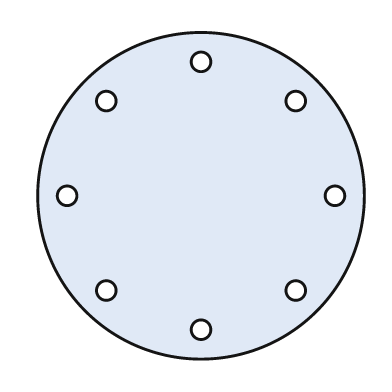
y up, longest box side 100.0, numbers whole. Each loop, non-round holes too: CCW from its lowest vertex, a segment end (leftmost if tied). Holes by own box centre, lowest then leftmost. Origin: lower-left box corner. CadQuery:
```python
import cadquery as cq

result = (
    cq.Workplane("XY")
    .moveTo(50.0, 50.0)
    .circle(50.0)
    .moveTo(50.0, 9.0)
    .circle(3.0)
    .moveTo(21.0, 21.0)
    .circle(3.0)
    .moveTo(79.0, 21.0)
    .circle(3.0)
    .moveTo(9.0, 50.0)
    .circle(3.0)
    .moveTo(91.0, 50.0)
    .circle(3.0)
    .moveTo(21.0, 79.0)
    .circle(3.0)
    .moveTo(79.0, 79.0)
    .circle(3.0)
    .moveTo(50.0, 91.0)
    .circle(3.0)
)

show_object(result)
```